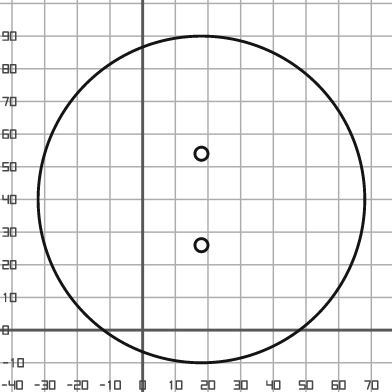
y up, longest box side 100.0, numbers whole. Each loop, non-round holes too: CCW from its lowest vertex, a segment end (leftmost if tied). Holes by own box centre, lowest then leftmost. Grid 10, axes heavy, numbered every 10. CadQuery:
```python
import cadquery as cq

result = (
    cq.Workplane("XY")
    .moveTo(18.0, 40.0)
    .circle(50.0)
    .moveTo(18.0, 26.0)
    .circle(2.0)
    .moveTo(18.0, 54.0)
    .circle(2.0)
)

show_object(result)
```